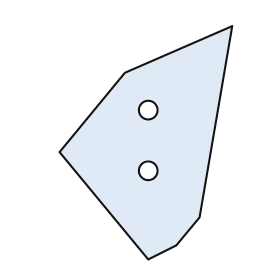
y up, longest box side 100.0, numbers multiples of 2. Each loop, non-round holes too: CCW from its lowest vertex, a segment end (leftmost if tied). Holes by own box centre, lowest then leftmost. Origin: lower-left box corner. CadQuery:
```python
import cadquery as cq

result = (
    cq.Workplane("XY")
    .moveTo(38.0, 0.0)
    .lineTo(50.0, 6.0)
    .lineTo(60.0, 18.0)
    .lineTo(74.0, 100.0)
    .lineTo(28.0, 80.0)
    .lineTo(0.0, 46.0)
    .close()
    .moveTo(38.0, 38.0)
    .circle(4.0)
    .moveTo(38.0, 64.0)
    .circle(4.0)
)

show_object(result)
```